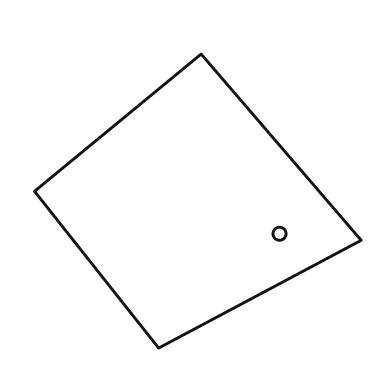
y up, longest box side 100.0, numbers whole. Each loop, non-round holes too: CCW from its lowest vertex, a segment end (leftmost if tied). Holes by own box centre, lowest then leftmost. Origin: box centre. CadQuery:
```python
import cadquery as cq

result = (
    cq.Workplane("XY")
    .moveTo(-12.0, -45.0)
    .lineTo(50.0, -12.0)
    .lineTo(1.0, 45.0)
    .lineTo(-50.0, 3.0)
    .close()
    .moveTo(25.0, -10.0)
    .circle(2.0)
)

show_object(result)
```